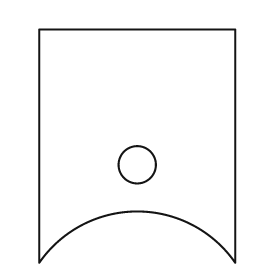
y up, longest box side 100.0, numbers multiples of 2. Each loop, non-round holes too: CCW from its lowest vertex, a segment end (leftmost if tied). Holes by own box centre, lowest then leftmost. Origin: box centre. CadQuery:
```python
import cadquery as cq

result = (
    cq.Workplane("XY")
    .moveTo(-42.0, -50.0)
    .threePointArc((0.0, -28.0), (42.0, -50.0))
    .lineTo(42.0, 50.0)
    .lineTo(-42.0, 50.0)
    .close()
    .moveTo(0.0, -8.0)
    .circle(8.0)
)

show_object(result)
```